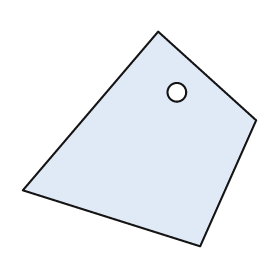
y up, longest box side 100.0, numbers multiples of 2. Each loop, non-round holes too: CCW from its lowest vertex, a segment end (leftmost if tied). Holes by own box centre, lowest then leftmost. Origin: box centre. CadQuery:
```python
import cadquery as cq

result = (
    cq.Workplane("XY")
    .moveTo(26.0, -46.0)
    .lineTo(50.0, 8.0)
    .lineTo(8.0, 46.0)
    .lineTo(-50.0, -22.0)
    .close()
    .moveTo(16.0, 20.0)
    .circle(4.0)
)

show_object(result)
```